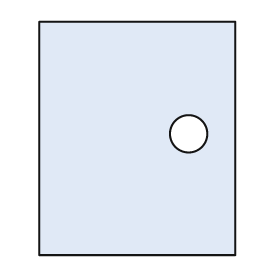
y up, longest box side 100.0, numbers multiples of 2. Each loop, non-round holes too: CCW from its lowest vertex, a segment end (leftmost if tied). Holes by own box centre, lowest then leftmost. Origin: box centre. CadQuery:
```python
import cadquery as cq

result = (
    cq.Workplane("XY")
    .moveTo(-42.0, -50.0)
    .lineTo(42.0, -50.0)
    .lineTo(42.0, 50.0)
    .lineTo(-42.0, 50.0)
    .close()
    .moveTo(22.0, 2.0)
    .circle(8.0)
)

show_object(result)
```